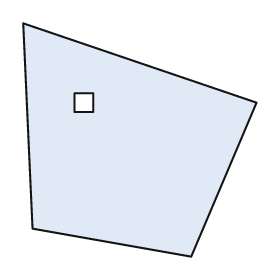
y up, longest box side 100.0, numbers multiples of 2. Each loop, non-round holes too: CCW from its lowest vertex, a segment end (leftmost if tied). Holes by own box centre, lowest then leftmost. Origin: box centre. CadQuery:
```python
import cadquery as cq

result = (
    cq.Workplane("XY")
    .moveTo(22.0, -50.0)
    .lineTo(50.0, 16.0)
    .lineTo(-50.0, 50.0)
    .lineTo(-46.0, -38.0)
    .close()
    .moveTo(-28.0, 12.0)
    .lineTo(-20.0, 12.0)
    .lineTo(-20.0, 20.0)
    .lineTo(-28.0, 20.0)
    .close()
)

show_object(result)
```